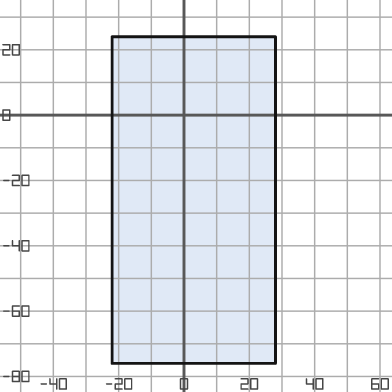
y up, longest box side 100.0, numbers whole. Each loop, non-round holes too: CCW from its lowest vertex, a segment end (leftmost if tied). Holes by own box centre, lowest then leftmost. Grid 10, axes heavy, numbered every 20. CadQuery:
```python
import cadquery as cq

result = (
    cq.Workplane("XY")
    .moveTo(-22.0, -76.0)
    .lineTo(28.0, -76.0)
    .lineTo(28.0, 24.0)
    .lineTo(-22.0, 24.0)
    .close()
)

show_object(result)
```